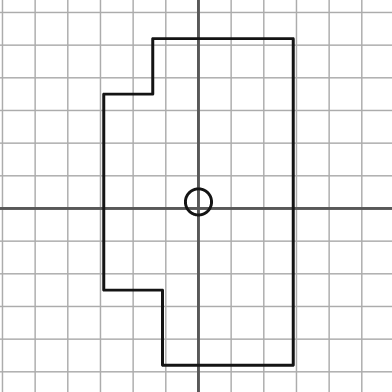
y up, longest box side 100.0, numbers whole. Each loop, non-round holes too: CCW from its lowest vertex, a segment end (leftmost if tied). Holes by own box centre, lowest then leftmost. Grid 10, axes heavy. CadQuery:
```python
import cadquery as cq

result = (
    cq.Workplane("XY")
    .moveTo(-11.0, -48.0)
    .lineTo(29.0, -48.0)
    .lineTo(29.0, 52.0)
    .lineTo(-14.0, 52.0)
    .lineTo(-14.0, 35.0)
    .lineTo(-29.0, 35.0)
    .lineTo(-29.0, -25.0)
    .lineTo(-11.0, -25.0)
    .close()
    .moveTo(0.0, 2.0)
    .circle(4.0)
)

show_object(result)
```